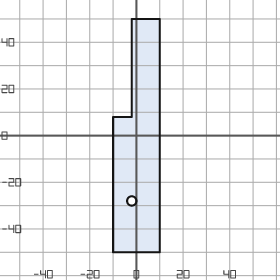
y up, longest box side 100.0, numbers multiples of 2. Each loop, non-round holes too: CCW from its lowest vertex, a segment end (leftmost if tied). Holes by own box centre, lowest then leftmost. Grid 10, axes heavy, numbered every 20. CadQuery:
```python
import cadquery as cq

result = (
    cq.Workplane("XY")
    .moveTo(-10.0, -50.0)
    .lineTo(10.0, -50.0)
    .lineTo(10.0, 50.0)
    .lineTo(-2.0, 50.0)
    .lineTo(-2.0, 8.0)
    .lineTo(-10.0, 8.0)
    .close()
    .moveTo(-2.0, -28.0)
    .circle(2.0)
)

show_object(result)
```